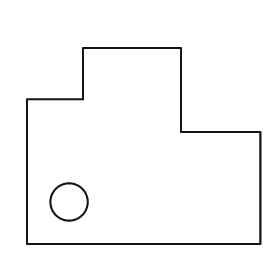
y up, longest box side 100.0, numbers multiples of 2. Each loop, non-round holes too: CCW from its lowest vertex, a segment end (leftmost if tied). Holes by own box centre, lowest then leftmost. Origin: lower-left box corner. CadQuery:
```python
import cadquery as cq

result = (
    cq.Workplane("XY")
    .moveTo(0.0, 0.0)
    .lineTo(100.0, 0.0)
    .lineTo(100.0, 48.0)
    .lineTo(66.0, 48.0)
    .lineTo(66.0, 84.0)
    .lineTo(24.0, 84.0)
    .lineTo(24.0, 62.0)
    .lineTo(0.0, 62.0)
    .close()
    .moveTo(18.0, 18.0)
    .circle(8.0)
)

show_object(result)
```